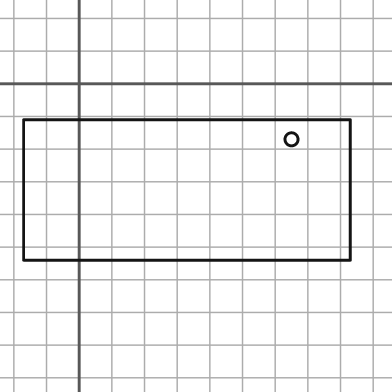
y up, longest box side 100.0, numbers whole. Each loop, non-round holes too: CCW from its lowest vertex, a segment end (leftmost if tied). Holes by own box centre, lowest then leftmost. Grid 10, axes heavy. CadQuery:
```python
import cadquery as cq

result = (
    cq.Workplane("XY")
    .moveTo(-17.0, -54.0)
    .lineTo(83.0, -54.0)
    .lineTo(83.0, -11.0)
    .lineTo(-17.0, -11.0)
    .close()
    .moveTo(65.0, -17.0)
    .circle(2.0)
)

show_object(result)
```